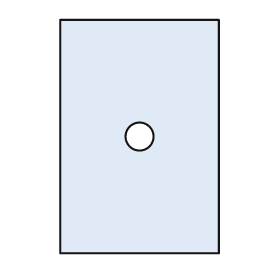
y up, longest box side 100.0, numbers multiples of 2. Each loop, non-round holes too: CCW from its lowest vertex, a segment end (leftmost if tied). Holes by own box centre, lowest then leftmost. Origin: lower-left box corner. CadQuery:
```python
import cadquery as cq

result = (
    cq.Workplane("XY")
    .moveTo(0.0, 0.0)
    .lineTo(68.0, 0.0)
    .lineTo(68.0, 100.0)
    .lineTo(0.0, 100.0)
    .close()
    .moveTo(34.0, 50.0)
    .circle(6.0)
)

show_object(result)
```